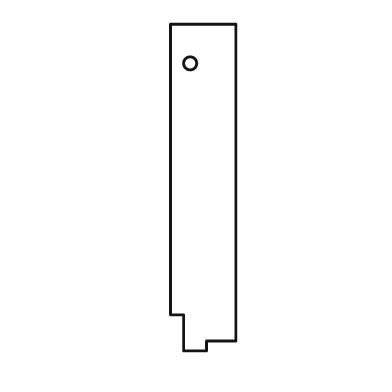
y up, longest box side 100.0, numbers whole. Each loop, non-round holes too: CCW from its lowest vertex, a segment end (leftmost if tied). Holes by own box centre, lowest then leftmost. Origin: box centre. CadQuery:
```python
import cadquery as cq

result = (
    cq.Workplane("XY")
    .moveTo(-6.0, -50.0)
    .lineTo(1.0, -50.0)
    .lineTo(1.0, -47.0)
    .lineTo(10.0, -47.0)
    .lineTo(10.0, 50.0)
    .lineTo(-10.0, 50.0)
    .lineTo(-10.0, -39.0)
    .lineTo(-6.0, -39.0)
    .close()
    .moveTo(-4.0, 38.0)
    .circle(2.0)
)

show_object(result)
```